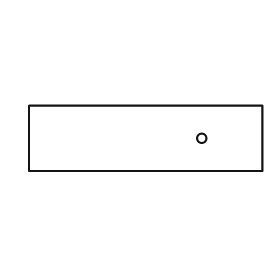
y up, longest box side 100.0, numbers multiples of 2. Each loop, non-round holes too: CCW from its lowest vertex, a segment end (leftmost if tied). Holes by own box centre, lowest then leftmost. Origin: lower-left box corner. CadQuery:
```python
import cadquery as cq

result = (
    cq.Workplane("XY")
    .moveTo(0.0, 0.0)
    .lineTo(100.0, 0.0)
    .lineTo(100.0, 28.0)
    .lineTo(0.0, 28.0)
    .close()
    .moveTo(74.0, 14.0)
    .circle(2.0)
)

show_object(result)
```